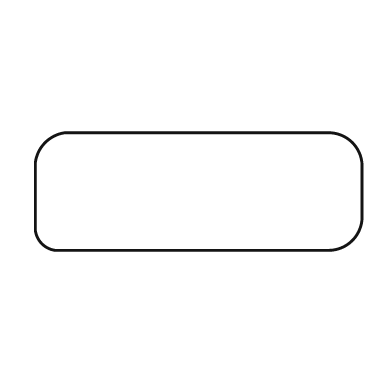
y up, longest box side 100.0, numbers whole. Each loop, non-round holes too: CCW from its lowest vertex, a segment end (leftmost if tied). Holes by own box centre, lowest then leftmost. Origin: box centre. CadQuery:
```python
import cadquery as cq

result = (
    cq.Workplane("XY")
    .moveTo(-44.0, -18.0)
    .lineTo(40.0, -18.0)
    .threePointArc((47.0, -15.0), (50.0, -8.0))
    .lineTo(50.0, 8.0)
    .threePointArc((47.0, 15.0), (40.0, 18.0))
    .lineTo(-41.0, 18.0)
    .threePointArc((-47.0, 15.0), (-50.0, 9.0))
    .lineTo(-50.0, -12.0)
    .threePointArc((-48.0, -16.0), (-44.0, -18.0))
    .close()
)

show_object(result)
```